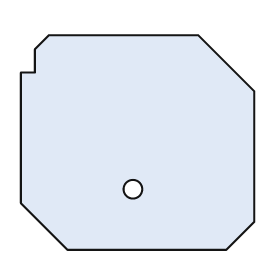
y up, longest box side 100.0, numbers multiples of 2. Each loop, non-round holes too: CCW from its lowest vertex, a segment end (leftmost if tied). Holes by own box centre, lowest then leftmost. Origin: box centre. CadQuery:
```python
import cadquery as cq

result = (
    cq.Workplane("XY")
    .moveTo(-30.0, -46.0)
    .lineTo(38.0, -46.0)
    .lineTo(50.0, -34.0)
    .lineTo(50.0, 22.0)
    .lineTo(26.0, 46.0)
    .lineTo(-38.0, 46.0)
    .lineTo(-44.0, 40.0)
    .lineTo(-44.0, 30.0)
    .lineTo(-50.0, 30.0)
    .lineTo(-50.0, -26.0)
    .close()
    .moveTo(-2.0, -20.0)
    .circle(4.0)
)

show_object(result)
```